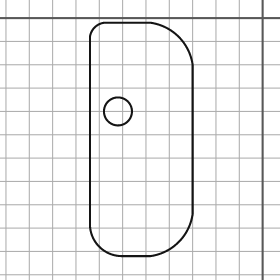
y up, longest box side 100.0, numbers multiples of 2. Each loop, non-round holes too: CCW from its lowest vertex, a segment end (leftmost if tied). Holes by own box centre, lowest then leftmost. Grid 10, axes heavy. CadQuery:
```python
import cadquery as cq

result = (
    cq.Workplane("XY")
    .moveTo(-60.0, -102.0)
    .lineTo(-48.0, -102.0)
    .threePointArc((-36.0, -96.0), (-30.0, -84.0))
    .lineTo(-30.0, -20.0)
    .threePointArc((-36.0, -8.0), (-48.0, -2.0))
    .lineTo(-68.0, -2.0)
    .threePointArc((-72.0, -4.0), (-74.0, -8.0))
    .lineTo(-74.0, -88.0)
    .threePointArc((-70.0, -98.0), (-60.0, -102.0))
    .close()
    .moveTo(-62.0, -40.0)
    .circle(6.0)
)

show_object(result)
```